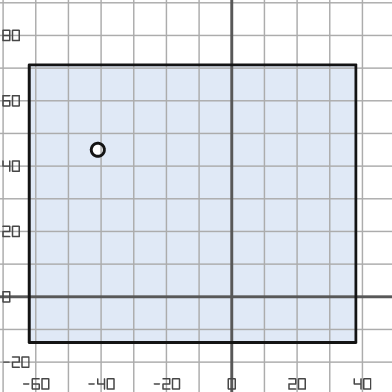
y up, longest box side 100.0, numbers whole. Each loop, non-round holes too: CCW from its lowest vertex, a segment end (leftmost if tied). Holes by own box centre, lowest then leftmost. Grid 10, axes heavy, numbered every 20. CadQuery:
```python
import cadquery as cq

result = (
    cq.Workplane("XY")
    .moveTo(-62.0, -14.0)
    .lineTo(38.0, -14.0)
    .lineTo(38.0, 71.0)
    .lineTo(-62.0, 71.0)
    .close()
    .moveTo(-41.0, 45.0)
    .circle(2.0)
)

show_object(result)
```